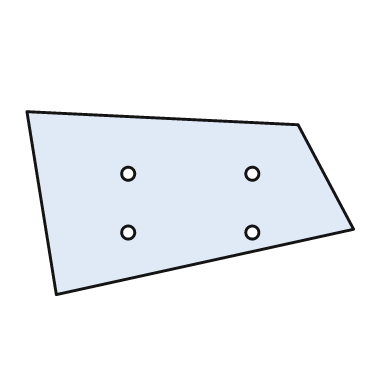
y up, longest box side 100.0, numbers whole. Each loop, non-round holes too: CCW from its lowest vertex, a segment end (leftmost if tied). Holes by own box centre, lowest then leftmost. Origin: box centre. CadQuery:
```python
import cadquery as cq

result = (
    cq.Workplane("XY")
    .moveTo(-41.0, -28.0)
    .lineTo(50.0, -8.0)
    .lineTo(33.0, 24.0)
    .lineTo(-50.0, 28.0)
    .close()
    .moveTo(-19.0, -9.0)
    .circle(2.0)
    .moveTo(19.0, -9.0)
    .circle(2.0)
    .moveTo(-19.0, 9.0)
    .circle(2.0)
    .moveTo(19.0, 9.0)
    .circle(2.0)
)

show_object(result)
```